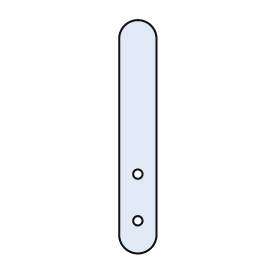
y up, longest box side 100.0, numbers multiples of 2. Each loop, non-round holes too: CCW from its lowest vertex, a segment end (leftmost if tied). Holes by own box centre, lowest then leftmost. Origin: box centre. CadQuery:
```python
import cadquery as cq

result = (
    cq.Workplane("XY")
    .moveTo(-8.0, -42.0)
    .threePointArc((0.0, -50.0), (8.0, -42.0))
    .lineTo(8.0, 42.0)
    .threePointArc((0.0, 50.0), (-8.0, 42.0))
    .close()
    .moveTo(0.0, -36.0)
    .circle(2.0)
    .moveTo(0.0, -16.0)
    .circle(2.0)
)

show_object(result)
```